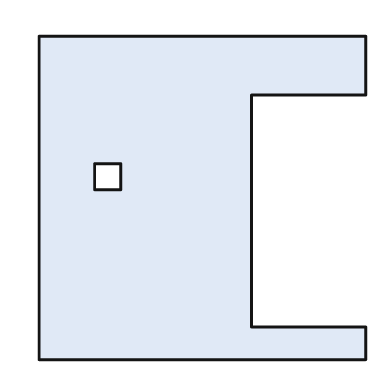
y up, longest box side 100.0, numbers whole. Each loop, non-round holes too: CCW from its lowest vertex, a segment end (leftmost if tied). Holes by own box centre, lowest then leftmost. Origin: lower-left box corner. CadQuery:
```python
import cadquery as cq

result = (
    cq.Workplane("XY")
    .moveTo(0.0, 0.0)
    .lineTo(100.0, 0.0)
    .lineTo(100.0, 10.0)
    .lineTo(65.0, 10.0)
    .lineTo(65.0, 81.0)
    .lineTo(100.0, 81.0)
    .lineTo(100.0, 99.0)
    .lineTo(0.0, 99.0)
    .close()
    .moveTo(17.0, 52.0)
    .lineTo(25.0, 52.0)
    .lineTo(25.0, 60.0)
    .lineTo(17.0, 60.0)
    .close()
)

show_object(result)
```